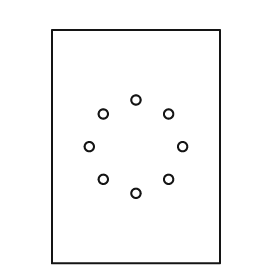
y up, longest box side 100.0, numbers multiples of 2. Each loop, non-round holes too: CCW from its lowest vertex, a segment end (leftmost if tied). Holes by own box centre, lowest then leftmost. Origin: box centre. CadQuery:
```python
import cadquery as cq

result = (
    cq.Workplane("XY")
    .moveTo(-36.0, -50.0)
    .lineTo(36.0, -50.0)
    .lineTo(36.0, 50.0)
    .lineTo(-36.0, 50.0)
    .close()
    .moveTo(0.0, -20.0)
    .circle(2.0)
    .moveTo(-14.0, -14.0)
    .circle(2.0)
    .moveTo(14.0, -14.0)
    .circle(2.0)
    .moveTo(-20.0, 0.0)
    .circle(2.0)
    .moveTo(20.0, 0.0)
    .circle(2.0)
    .moveTo(-14.0, 14.0)
    .circle(2.0)
    .moveTo(14.0, 14.0)
    .circle(2.0)
    .moveTo(0.0, 20.0)
    .circle(2.0)
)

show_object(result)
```